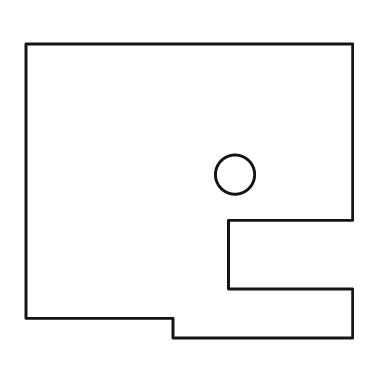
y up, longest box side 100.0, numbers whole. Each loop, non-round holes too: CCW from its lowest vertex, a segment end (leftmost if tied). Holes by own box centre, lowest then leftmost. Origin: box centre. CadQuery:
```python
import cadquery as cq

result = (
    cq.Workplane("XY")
    .moveTo(-5.0, -45.0)
    .lineTo(50.0, -45.0)
    .lineTo(50.0, -30.0)
    .lineTo(12.0, -30.0)
    .lineTo(12.0, -9.0)
    .lineTo(50.0, -9.0)
    .lineTo(50.0, 45.0)
    .lineTo(-50.0, 45.0)
    .lineTo(-50.0, -39.0)
    .lineTo(-5.0, -39.0)
    .close()
    .moveTo(14.0, 5.0)
    .circle(6.0)
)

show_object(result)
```